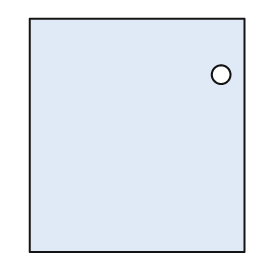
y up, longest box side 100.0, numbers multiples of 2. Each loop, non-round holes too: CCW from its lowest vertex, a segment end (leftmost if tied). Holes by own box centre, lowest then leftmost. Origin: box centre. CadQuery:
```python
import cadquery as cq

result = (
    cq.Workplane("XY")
    .moveTo(-46.0, -50.0)
    .lineTo(46.0, -50.0)
    .lineTo(46.0, 50.0)
    .lineTo(-46.0, 50.0)
    .close()
    .moveTo(36.0, 26.0)
    .circle(4.0)
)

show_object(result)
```